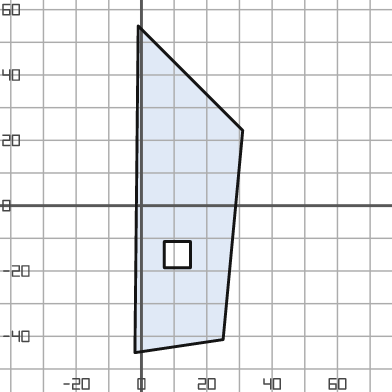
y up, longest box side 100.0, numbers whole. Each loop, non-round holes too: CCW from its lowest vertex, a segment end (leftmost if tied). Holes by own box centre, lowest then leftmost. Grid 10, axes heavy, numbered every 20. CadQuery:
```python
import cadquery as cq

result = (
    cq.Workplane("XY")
    .moveTo(-2.0, -45.0)
    .lineTo(25.0, -41.0)
    .lineTo(31.0, 23.0)
    .lineTo(-1.0, 55.0)
    .close()
    .moveTo(7.0, -19.0)
    .lineTo(15.0, -19.0)
    .lineTo(15.0, -11.0)
    .lineTo(7.0, -11.0)
    .close()
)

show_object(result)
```